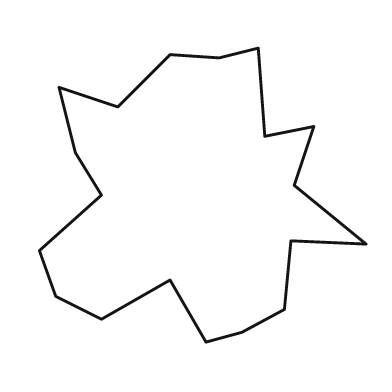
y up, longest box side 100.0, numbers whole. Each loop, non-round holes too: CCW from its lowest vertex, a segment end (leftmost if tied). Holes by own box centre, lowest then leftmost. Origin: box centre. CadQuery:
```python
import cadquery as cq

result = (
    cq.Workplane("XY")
    .moveTo(1.0, -45.0)
    .lineTo(12.0, -42.0)
    .lineTo(25.0, -35.0)
    .lineTo(27.0, -14.0)
    .lineTo(50.0, -15.0)
    .lineTo(28.0, 3.0)
    .lineTo(34.0, 21.0)
    .lineTo(19.0, 18.0)
    .lineTo(17.0, 45.0)
    .lineTo(5.0, 42.0)
    .lineTo(-10.0, 43.0)
    .lineTo(-26.0, 27.0)
    .lineTo(-44.0, 33.0)
    .lineTo(-39.0, 13.0)
    .lineTo(-31.0, 0.0)
    .lineTo(-50.0, -17.0)
    .lineTo(-45.0, -31.0)
    .lineTo(-31.0, -38.0)
    .lineTo(-10.0, -26.0)
    .close()
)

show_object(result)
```